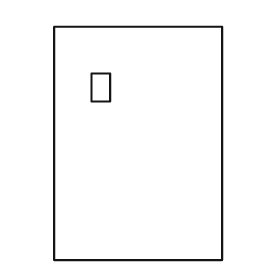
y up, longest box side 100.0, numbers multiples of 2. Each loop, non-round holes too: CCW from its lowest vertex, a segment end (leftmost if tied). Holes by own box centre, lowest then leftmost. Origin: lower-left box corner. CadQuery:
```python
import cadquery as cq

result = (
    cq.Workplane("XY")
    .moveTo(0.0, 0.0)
    .lineTo(72.0, 0.0)
    .lineTo(72.0, 100.0)
    .lineTo(0.0, 100.0)
    .close()
    .moveTo(16.0, 68.0)
    .lineTo(24.0, 68.0)
    .lineTo(24.0, 80.0)
    .lineTo(16.0, 80.0)
    .close()
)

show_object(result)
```